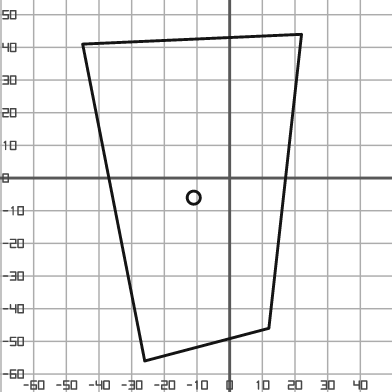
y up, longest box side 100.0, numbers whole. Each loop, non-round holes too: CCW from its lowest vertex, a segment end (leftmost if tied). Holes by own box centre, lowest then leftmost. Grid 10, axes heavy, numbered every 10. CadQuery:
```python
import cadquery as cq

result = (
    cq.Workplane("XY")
    .moveTo(-26.0, -56.0)
    .lineTo(12.0, -46.0)
    .lineTo(22.0, 44.0)
    .lineTo(-45.0, 41.0)
    .close()
    .moveTo(-11.0, -6.0)
    .circle(2.0)
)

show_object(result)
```